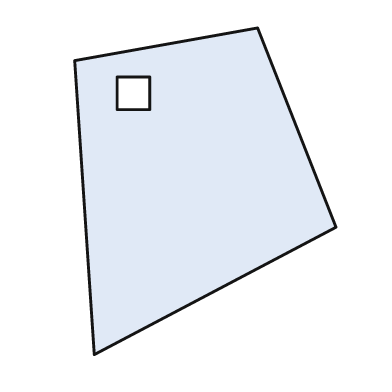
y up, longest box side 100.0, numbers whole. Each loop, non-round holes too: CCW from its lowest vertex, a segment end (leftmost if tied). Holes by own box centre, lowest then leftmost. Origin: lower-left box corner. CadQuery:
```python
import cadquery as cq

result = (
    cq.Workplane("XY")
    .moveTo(6.0, 0.0)
    .lineTo(80.0, 39.0)
    .lineTo(56.0, 100.0)
    .lineTo(0.0, 90.0)
    .close()
    .moveTo(13.0, 75.0)
    .lineTo(23.0, 75.0)
    .lineTo(23.0, 85.0)
    .lineTo(13.0, 85.0)
    .close()
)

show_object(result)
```